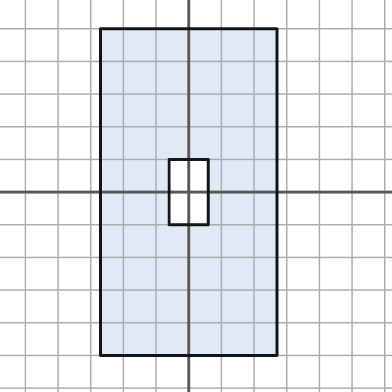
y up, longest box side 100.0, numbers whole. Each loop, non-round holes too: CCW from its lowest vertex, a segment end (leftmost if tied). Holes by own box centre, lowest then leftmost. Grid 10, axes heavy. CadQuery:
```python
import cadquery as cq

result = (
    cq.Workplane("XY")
    .moveTo(-27.0, -50.0)
    .lineTo(27.0, -50.0)
    .lineTo(27.0, 50.0)
    .lineTo(-27.0, 50.0)
    .close()
    .moveTo(-6.0, -10.0)
    .lineTo(6.0, -10.0)
    .lineTo(6.0, 10.0)
    .lineTo(-6.0, 10.0)
    .close()
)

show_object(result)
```